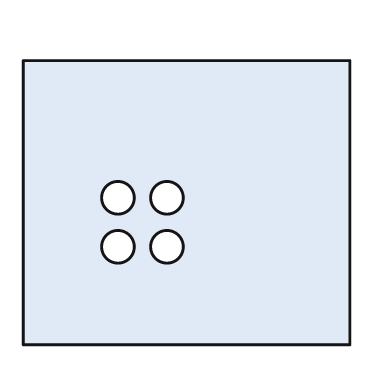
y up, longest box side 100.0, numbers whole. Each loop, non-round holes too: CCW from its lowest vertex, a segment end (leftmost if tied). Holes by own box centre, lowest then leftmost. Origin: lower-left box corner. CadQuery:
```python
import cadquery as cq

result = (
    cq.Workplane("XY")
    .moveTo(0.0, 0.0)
    .lineTo(100.0, 0.0)
    .lineTo(100.0, 87.0)
    .lineTo(0.0, 87.0)
    .close()
    .moveTo(29.0, 30.0)
    .circle(5.0)
    .moveTo(44.0, 30.0)
    .circle(5.0)
    .moveTo(29.0, 45.0)
    .circle(5.0)
    .moveTo(44.0, 45.0)
    .circle(5.0)
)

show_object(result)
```